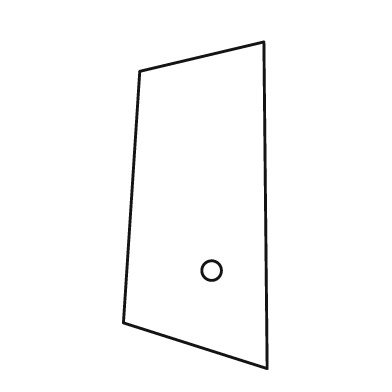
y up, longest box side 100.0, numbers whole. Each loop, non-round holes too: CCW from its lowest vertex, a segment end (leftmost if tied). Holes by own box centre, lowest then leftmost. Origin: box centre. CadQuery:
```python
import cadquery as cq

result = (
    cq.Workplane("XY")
    .moveTo(22.0, -50.0)
    .lineTo(21.0, 50.0)
    .lineTo(-17.0, 41.0)
    .lineTo(-22.0, -36.0)
    .close()
    .moveTo(5.0, -20.0)
    .circle(3.0)
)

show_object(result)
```